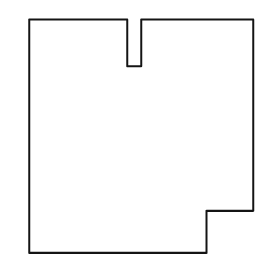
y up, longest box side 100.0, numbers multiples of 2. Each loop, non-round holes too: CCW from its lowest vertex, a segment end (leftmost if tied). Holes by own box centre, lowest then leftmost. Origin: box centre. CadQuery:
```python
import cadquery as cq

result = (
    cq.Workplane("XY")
    .moveTo(-48.0, -50.0)
    .lineTo(28.0, -50.0)
    .lineTo(28.0, -32.0)
    .lineTo(48.0, -32.0)
    .lineTo(48.0, 50.0)
    .lineTo(0.0, 50.0)
    .lineTo(0.0, 30.0)
    .lineTo(-6.0, 30.0)
    .lineTo(-6.0, 50.0)
    .lineTo(-48.0, 50.0)
    .close()
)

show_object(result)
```